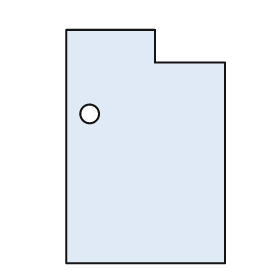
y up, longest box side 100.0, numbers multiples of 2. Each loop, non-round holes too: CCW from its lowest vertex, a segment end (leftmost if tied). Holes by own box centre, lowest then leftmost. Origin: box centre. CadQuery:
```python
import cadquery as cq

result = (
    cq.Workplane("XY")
    .moveTo(-34.0, -50.0)
    .lineTo(34.0, -50.0)
    .lineTo(34.0, 36.0)
    .lineTo(4.0, 36.0)
    .lineTo(4.0, 50.0)
    .lineTo(-34.0, 50.0)
    .close()
    .moveTo(-24.0, 14.0)
    .circle(4.0)
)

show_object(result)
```